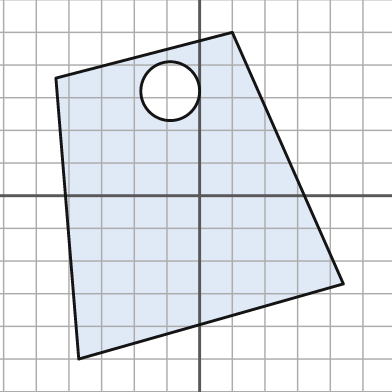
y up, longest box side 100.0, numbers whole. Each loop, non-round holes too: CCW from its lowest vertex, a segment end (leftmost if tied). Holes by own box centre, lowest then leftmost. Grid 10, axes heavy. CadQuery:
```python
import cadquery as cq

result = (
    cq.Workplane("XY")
    .moveTo(-37.0, -50.0)
    .lineTo(44.0, -27.0)
    .lineTo(10.0, 50.0)
    .lineTo(-44.0, 36.0)
    .close()
    .moveTo(-9.0, 32.0)
    .circle(9.0)
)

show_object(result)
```